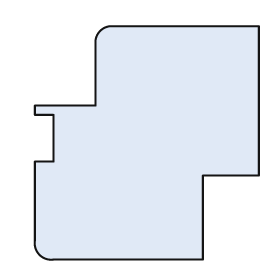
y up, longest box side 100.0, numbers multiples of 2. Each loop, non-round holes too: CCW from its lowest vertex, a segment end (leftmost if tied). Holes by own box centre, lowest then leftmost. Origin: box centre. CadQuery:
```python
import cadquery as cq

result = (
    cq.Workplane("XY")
    .moveTo(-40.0, -50.0)
    .lineTo(24.0, -50.0)
    .lineTo(24.0, -14.0)
    .lineTo(48.0, -14.0)
    .lineTo(48.0, 50.0)
    .lineTo(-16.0, 50.0)
    .threePointArc((-20.0, 48.0), (-22.0, 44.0))
    .lineTo(-22.0, 16.0)
    .lineTo(-48.0, 16.0)
    .lineTo(-48.0, 12.0)
    .lineTo(-40.0, 12.0)
    .lineTo(-40.0, -8.0)
    .lineTo(-48.0, -8.0)
    .lineTo(-48.0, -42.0)
    .threePointArc((-46.0, -48.0), (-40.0, -50.0))
    .close()
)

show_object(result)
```